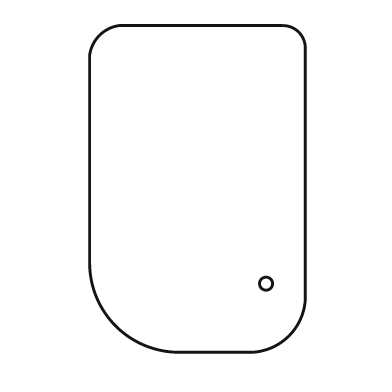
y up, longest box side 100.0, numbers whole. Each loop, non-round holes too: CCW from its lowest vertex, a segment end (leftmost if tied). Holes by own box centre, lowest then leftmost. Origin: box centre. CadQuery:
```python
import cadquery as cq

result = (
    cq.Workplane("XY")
    .moveTo(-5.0, -50.0)
    .lineTo(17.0, -50.0)
    .threePointArc((28.0, -45.0), (33.0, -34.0))
    .lineTo(33.0, 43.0)
    .threePointArc((31.0, 48.0), (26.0, 50.0))
    .lineTo(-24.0, 50.0)
    .threePointArc((-30.0, 47.0), (-33.0, 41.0))
    .lineTo(-33.0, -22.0)
    .threePointArc((-25.0, -42.0), (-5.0, -50.0))
    .close()
    .moveTo(21.0, -29.0)
    .circle(2.0)
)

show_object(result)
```